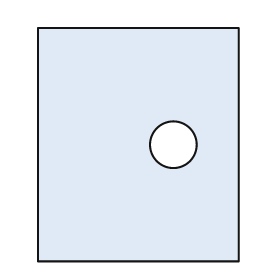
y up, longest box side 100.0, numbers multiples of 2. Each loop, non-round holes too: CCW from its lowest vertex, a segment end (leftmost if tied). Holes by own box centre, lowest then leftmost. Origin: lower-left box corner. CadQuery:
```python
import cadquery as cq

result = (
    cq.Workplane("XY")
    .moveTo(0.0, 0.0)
    .lineTo(86.0, 0.0)
    .lineTo(86.0, 100.0)
    .lineTo(0.0, 100.0)
    .close()
    .moveTo(58.0, 50.0)
    .circle(10.0)
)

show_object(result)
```